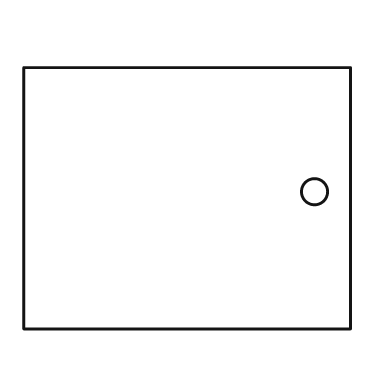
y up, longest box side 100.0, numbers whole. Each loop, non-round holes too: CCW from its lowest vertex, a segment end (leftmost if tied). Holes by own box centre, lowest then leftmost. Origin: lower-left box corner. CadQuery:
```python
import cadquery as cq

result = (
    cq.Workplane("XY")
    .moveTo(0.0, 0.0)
    .lineTo(100.0, 0.0)
    .lineTo(100.0, 80.0)
    .lineTo(0.0, 80.0)
    .close()
    .moveTo(89.0, 42.0)
    .circle(4.0)
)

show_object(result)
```